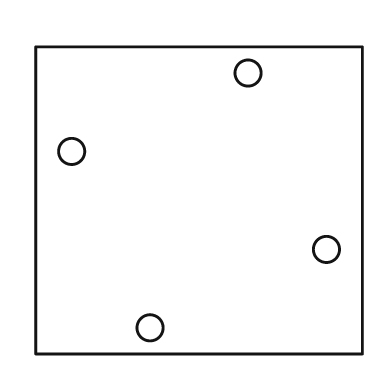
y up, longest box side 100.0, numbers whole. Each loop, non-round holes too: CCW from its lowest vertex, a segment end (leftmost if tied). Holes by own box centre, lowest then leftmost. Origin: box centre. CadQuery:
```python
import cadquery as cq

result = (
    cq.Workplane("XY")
    .moveTo(-50.0, -47.0)
    .lineTo(50.0, -47.0)
    .lineTo(50.0, 47.0)
    .lineTo(-50.0, 47.0)
    .close()
    .moveTo(-15.0, -39.0)
    .circle(4.0)
    .moveTo(39.0, -15.0)
    .circle(4.0)
    .moveTo(-39.0, 15.0)
    .circle(4.0)
    .moveTo(15.0, 39.0)
    .circle(4.0)
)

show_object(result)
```